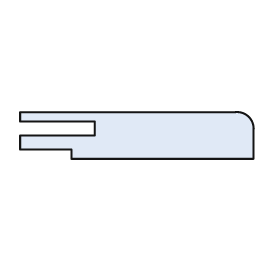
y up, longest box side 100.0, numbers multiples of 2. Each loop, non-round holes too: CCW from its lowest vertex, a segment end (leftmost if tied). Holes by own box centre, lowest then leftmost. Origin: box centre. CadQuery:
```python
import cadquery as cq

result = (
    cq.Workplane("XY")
    .moveTo(-28.0, -10.0)
    .lineTo(50.0, -10.0)
    .lineTo(50.0, 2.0)
    .threePointArc((48.0, 8.0), (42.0, 10.0))
    .lineTo(-50.0, 10.0)
    .lineTo(-50.0, 6.0)
    .lineTo(-18.0, 6.0)
    .lineTo(-18.0, 0.0)
    .lineTo(-50.0, 0.0)
    .lineTo(-50.0, -6.0)
    .lineTo(-28.0, -6.0)
    .close()
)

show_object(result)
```